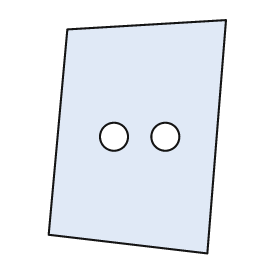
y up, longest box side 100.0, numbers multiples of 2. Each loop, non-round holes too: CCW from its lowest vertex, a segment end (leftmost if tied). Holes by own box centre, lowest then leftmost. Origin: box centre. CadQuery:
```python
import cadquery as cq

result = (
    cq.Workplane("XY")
    .moveTo(30.0, -50.0)
    .lineTo(38.0, 50.0)
    .lineTo(-30.0, 46.0)
    .lineTo(-38.0, -42.0)
    .close()
    .moveTo(-10.0, 0.0)
    .circle(6.0)
    .moveTo(12.0, 0.0)
    .circle(6.0)
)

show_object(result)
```